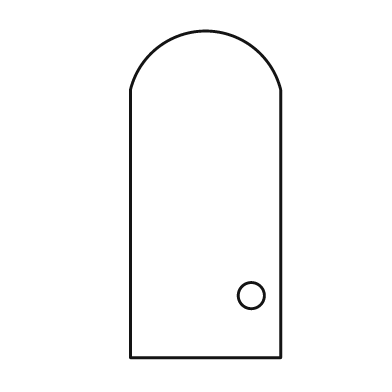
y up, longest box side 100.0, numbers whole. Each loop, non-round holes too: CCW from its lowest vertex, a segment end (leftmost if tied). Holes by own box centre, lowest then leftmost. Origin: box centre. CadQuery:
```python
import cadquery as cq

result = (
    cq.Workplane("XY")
    .moveTo(-23.0, -50.0)
    .lineTo(23.0, -50.0)
    .lineTo(23.0, 32.0)
    .threePointArc((0.0, 50.0), (-23.0, 32.0))
    .close()
    .moveTo(14.0, -31.0)
    .circle(4.0)
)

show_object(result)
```